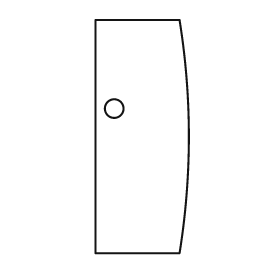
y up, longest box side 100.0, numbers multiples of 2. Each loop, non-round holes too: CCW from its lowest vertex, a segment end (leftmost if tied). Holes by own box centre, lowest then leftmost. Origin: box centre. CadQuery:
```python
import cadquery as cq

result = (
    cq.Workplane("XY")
    .moveTo(-20.0, -50.0)
    .lineTo(16.0, -50.0)
    .threePointArc((20.0, 0.0), (16.0, 50.0))
    .lineTo(-20.0, 50.0)
    .close()
    .moveTo(-12.0, 12.0)
    .circle(4.0)
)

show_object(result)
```